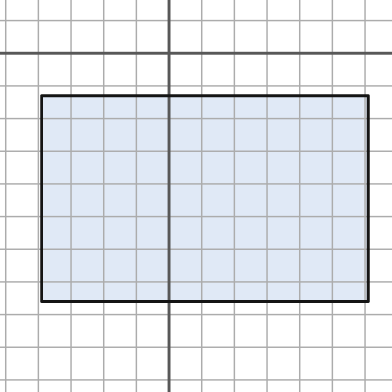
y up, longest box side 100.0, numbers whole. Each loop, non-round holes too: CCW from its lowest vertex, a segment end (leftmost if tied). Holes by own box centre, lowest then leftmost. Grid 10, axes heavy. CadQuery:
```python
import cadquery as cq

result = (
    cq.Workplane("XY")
    .moveTo(-39.0, -76.0)
    .lineTo(61.0, -76.0)
    .lineTo(61.0, -13.0)
    .lineTo(-39.0, -13.0)
    .close()
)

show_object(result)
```